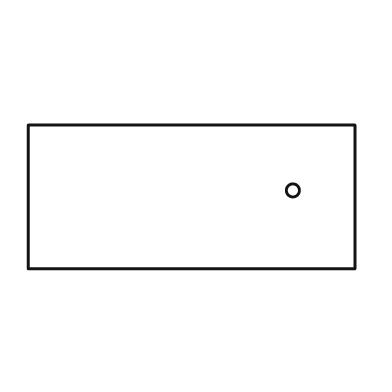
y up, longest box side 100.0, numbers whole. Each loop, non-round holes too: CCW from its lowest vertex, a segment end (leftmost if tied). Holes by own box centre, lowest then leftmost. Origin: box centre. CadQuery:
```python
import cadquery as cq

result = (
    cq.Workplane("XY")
    .moveTo(-50.0, -22.0)
    .lineTo(50.0, -22.0)
    .lineTo(50.0, 22.0)
    .lineTo(-50.0, 22.0)
    .close()
    .moveTo(31.0, 2.0)
    .circle(2.0)
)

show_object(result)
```